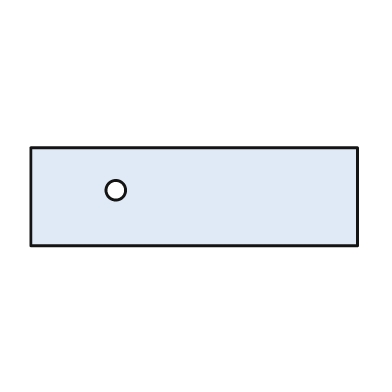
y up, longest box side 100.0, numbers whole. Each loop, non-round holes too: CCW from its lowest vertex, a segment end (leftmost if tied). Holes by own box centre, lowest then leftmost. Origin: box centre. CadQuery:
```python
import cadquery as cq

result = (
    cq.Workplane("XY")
    .moveTo(-50.0, -15.0)
    .lineTo(50.0, -15.0)
    .lineTo(50.0, 15.0)
    .lineTo(-50.0, 15.0)
    .close()
    .moveTo(-24.0, 2.0)
    .circle(3.0)
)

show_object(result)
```